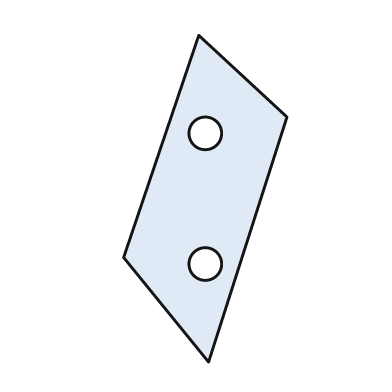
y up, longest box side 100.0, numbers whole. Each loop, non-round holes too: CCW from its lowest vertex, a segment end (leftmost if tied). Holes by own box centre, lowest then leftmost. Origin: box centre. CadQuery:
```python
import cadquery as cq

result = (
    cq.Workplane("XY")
    .moveTo(1.0, -50.0)
    .lineTo(25.0, 25.0)
    .lineTo(-2.0, 50.0)
    .lineTo(-25.0, -18.0)
    .close()
    .moveTo(0.0, -20.0)
    .circle(5.0)
    .moveTo(0.0, 20.0)
    .circle(5.0)
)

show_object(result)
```